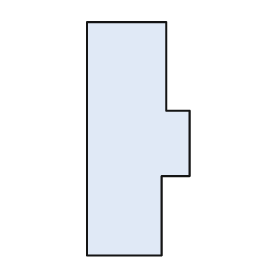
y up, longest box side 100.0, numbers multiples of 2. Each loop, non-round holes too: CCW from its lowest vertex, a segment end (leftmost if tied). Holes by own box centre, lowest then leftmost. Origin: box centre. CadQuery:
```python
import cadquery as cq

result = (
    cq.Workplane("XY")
    .moveTo(-22.0, -50.0)
    .lineTo(10.0, -50.0)
    .lineTo(10.0, -16.0)
    .lineTo(22.0, -16.0)
    .lineTo(22.0, 12.0)
    .lineTo(12.0, 12.0)
    .lineTo(12.0, 50.0)
    .lineTo(-22.0, 50.0)
    .close()
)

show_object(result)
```